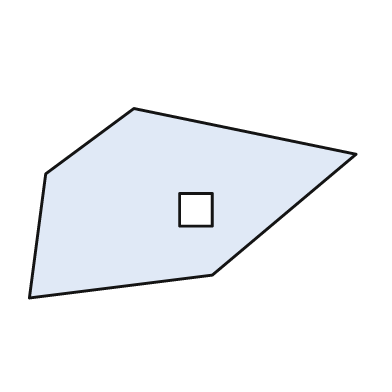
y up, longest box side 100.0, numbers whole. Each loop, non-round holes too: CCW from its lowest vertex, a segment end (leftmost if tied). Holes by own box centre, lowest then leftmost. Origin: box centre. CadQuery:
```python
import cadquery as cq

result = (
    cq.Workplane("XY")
    .moveTo(-50.0, -29.0)
    .lineTo(6.0, -22.0)
    .lineTo(50.0, 15.0)
    .lineTo(-18.0, 29.0)
    .lineTo(-45.0, 9.0)
    .close()
    .moveTo(-4.0, -7.0)
    .lineTo(6.0, -7.0)
    .lineTo(6.0, 3.0)
    .lineTo(-4.0, 3.0)
    .close()
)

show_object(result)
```